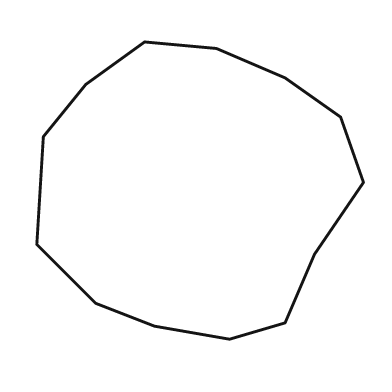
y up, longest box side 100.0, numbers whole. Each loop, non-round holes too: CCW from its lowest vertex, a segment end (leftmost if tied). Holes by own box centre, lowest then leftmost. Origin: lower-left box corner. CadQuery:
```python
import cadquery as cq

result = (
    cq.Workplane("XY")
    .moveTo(59.0, 0.0)
    .lineTo(76.0, 5.0)
    .lineTo(85.0, 26.0)
    .lineTo(100.0, 48.0)
    .lineTo(93.0, 68.0)
    .lineTo(76.0, 80.0)
    .lineTo(55.0, 89.0)
    .lineTo(33.0, 91.0)
    .lineTo(15.0, 78.0)
    .lineTo(2.0, 62.0)
    .lineTo(0.0, 29.0)
    .lineTo(18.0, 11.0)
    .lineTo(36.0, 4.0)
    .close()
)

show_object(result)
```